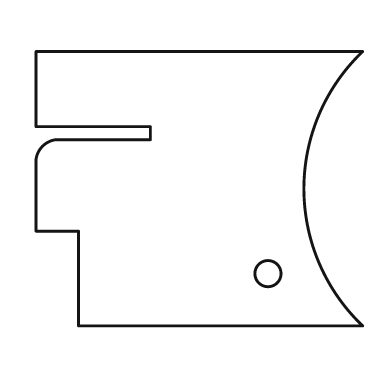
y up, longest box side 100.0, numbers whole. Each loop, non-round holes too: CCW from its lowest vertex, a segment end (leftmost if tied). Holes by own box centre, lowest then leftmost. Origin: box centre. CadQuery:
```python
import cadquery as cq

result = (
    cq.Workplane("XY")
    .moveTo(-37.0, -42.0)
    .lineTo(50.0, -42.0)
    .threePointArc((32.0, 0.0), (50.0, 42.0))
    .lineTo(-50.0, 42.0)
    .lineTo(-50.0, 19.0)
    .lineTo(-15.0, 19.0)
    .lineTo(-15.0, 15.0)
    .lineTo(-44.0, 15.0)
    .threePointArc((-48.0, 13.0), (-50.0, 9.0))
    .lineTo(-50.0, -13.0)
    .lineTo(-37.0, -13.0)
    .close()
    .moveTo(21.0, -26.0)
    .circle(4.0)
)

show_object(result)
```